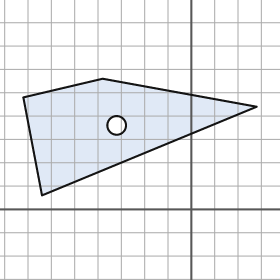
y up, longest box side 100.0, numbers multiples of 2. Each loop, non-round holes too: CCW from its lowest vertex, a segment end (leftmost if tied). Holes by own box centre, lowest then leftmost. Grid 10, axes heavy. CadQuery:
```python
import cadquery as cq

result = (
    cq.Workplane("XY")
    .moveTo(-64.0, 6.0)
    .lineTo(28.0, 44.0)
    .lineTo(-38.0, 56.0)
    .lineTo(-72.0, 48.0)
    .close()
    .moveTo(-32.0, 36.0)
    .circle(4.0)
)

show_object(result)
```